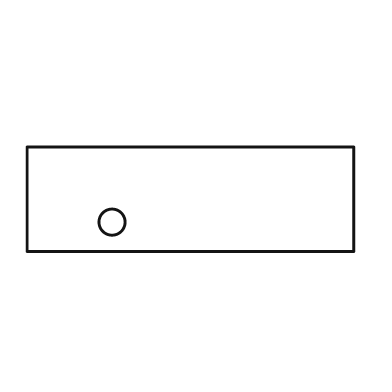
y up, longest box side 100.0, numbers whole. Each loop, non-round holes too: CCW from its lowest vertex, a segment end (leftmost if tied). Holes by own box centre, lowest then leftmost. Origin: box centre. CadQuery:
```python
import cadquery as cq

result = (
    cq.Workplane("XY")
    .moveTo(-50.0, -16.0)
    .lineTo(50.0, -16.0)
    .lineTo(50.0, 16.0)
    .lineTo(-50.0, 16.0)
    .close()
    .moveTo(-24.0, -7.0)
    .circle(4.0)
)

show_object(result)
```